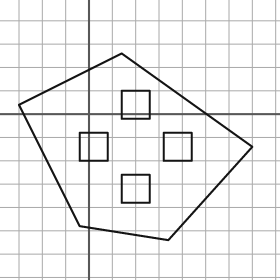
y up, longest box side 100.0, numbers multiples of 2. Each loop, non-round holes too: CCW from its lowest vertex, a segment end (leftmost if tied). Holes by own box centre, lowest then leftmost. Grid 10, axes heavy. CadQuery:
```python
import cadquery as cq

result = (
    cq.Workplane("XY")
    .moveTo(34.0, -54.0)
    .lineTo(70.0, -14.0)
    .lineTo(14.0, 26.0)
    .lineTo(-30.0, 4.0)
    .lineTo(-4.0, -48.0)
    .close()
    .moveTo(14.0, -38.0)
    .lineTo(26.0, -38.0)
    .lineTo(26.0, -26.0)
    .lineTo(14.0, -26.0)
    .close()
    .moveTo(-4.0, -20.0)
    .lineTo(8.0, -20.0)
    .lineTo(8.0, -8.0)
    .lineTo(-4.0, -8.0)
    .close()
    .moveTo(32.0, -20.0)
    .lineTo(44.0, -20.0)
    .lineTo(44.0, -8.0)
    .lineTo(32.0, -8.0)
    .close()
    .moveTo(14.0, -2.0)
    .lineTo(26.0, -2.0)
    .lineTo(26.0, 10.0)
    .lineTo(14.0, 10.0)
    .close()
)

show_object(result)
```